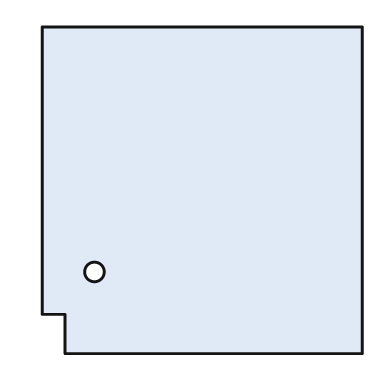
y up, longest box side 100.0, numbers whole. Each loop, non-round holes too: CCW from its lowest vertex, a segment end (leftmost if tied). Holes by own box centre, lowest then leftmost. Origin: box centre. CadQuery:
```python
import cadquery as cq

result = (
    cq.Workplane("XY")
    .moveTo(-42.0, -50.0)
    .lineTo(49.0, -50.0)
    .lineTo(49.0, 50.0)
    .lineTo(-49.0, 50.0)
    .lineTo(-49.0, -38.0)
    .lineTo(-42.0, -38.0)
    .close()
    .moveTo(-33.0, -25.0)
    .circle(3.0)
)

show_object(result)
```